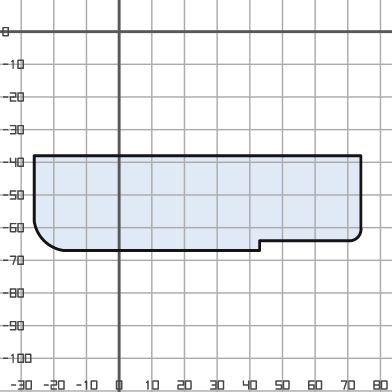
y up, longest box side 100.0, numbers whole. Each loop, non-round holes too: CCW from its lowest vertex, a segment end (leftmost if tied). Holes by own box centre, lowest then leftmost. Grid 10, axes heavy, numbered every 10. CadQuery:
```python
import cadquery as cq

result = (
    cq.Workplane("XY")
    .moveTo(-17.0, -67.0)
    .lineTo(43.0, -67.0)
    .lineTo(43.0, -64.0)
    .lineTo(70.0, -64.0)
    .threePointArc((73.0, -63.0), (74.0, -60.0))
    .lineTo(74.0, -38.0)
    .lineTo(-26.0, -38.0)
    .lineTo(-26.0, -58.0)
    .threePointArc((-23.0, -64.0), (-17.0, -67.0))
    .close()
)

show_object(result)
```